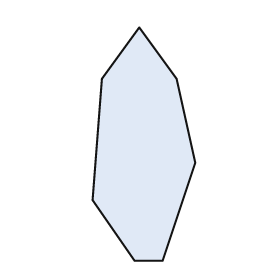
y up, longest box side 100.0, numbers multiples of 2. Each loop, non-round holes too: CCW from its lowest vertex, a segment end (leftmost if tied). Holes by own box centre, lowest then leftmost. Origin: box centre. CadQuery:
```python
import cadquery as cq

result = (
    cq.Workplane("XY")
    .moveTo(-4.0, -50.0)
    .lineTo(8.0, -50.0)
    .lineTo(22.0, -8.0)
    .lineTo(14.0, 28.0)
    .lineTo(-2.0, 50.0)
    .lineTo(-18.0, 28.0)
    .lineTo(-22.0, -24.0)
    .close()
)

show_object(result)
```